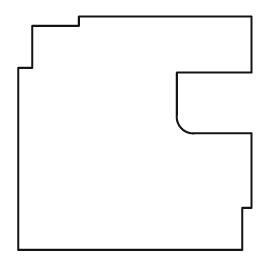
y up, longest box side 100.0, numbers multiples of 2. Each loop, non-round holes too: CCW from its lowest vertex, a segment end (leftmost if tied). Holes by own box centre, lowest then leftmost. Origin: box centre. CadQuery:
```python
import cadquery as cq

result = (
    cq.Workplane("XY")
    .moveTo(-50.0, -50.0)
    .lineTo(46.0, -50.0)
    .lineTo(46.0, -32.0)
    .lineTo(50.0, -32.0)
    .lineTo(50.0, 0.0)
    .lineTo(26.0, 0.0)
    .threePointArc((20.0, 2.0), (18.0, 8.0))
    .lineTo(18.0, 26.0)
    .lineTo(50.0, 26.0)
    .lineTo(50.0, 50.0)
    .lineTo(-24.0, 50.0)
    .lineTo(-24.0, 46.0)
    .lineTo(-44.0, 46.0)
    .lineTo(-44.0, 28.0)
    .lineTo(-50.0, 28.0)
    .close()
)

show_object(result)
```